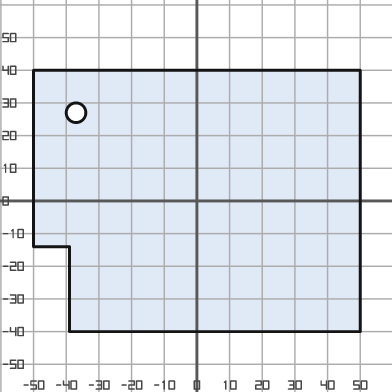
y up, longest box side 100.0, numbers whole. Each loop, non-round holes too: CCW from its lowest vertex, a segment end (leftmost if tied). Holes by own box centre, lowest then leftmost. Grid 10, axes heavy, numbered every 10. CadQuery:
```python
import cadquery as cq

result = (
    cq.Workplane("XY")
    .moveTo(-39.0, -40.0)
    .lineTo(50.0, -40.0)
    .lineTo(50.0, 40.0)
    .lineTo(-50.0, 40.0)
    .lineTo(-50.0, -14.0)
    .lineTo(-39.0, -14.0)
    .close()
    .moveTo(-37.0, 27.0)
    .circle(3.0)
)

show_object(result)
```